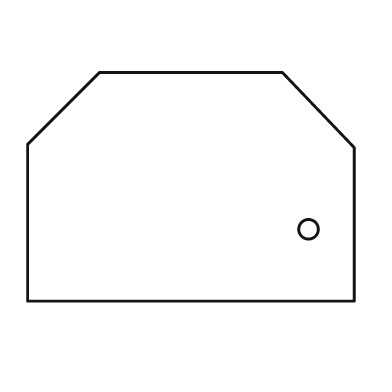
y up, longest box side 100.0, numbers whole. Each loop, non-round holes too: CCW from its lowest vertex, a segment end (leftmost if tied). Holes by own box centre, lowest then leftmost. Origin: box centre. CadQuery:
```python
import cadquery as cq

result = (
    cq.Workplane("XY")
    .moveTo(-50.0, -35.0)
    .lineTo(50.0, -35.0)
    .lineTo(50.0, 12.0)
    .lineTo(28.0, 35.0)
    .lineTo(-28.0, 35.0)
    .lineTo(-50.0, 13.0)
    .close()
    .moveTo(36.0, -13.0)
    .circle(3.0)
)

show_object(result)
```